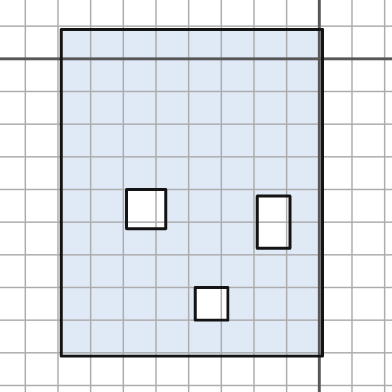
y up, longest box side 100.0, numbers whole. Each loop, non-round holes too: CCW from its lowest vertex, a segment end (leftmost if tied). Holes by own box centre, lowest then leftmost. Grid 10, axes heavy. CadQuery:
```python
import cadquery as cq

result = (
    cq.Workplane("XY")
    .moveTo(-79.0, -91.0)
    .lineTo(1.0, -91.0)
    .lineTo(1.0, 9.0)
    .lineTo(-79.0, 9.0)
    .close()
    .moveTo(-38.0, -80.0)
    .lineTo(-28.0, -80.0)
    .lineTo(-28.0, -70.0)
    .lineTo(-38.0, -70.0)
    .close()
    .moveTo(-19.0, -58.0)
    .lineTo(-9.0, -58.0)
    .lineTo(-9.0, -42.0)
    .lineTo(-19.0, -42.0)
    .close()
    .moveTo(-59.0, -52.0)
    .lineTo(-47.0, -52.0)
    .lineTo(-47.0, -40.0)
    .lineTo(-59.0, -40.0)
    .close()
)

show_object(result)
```